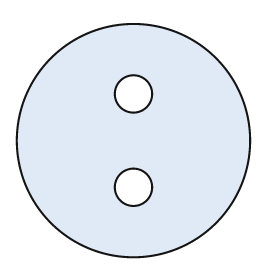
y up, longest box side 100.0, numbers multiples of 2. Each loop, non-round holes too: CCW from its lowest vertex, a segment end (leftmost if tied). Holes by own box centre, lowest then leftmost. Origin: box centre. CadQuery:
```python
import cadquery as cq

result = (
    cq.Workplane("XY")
    .moveTo(0.0, 0.0)
    .circle(50.0)
    .moveTo(0.0, -20.0)
    .circle(8.0)
    .moveTo(0.0, 20.0)
    .circle(8.0)
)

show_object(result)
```